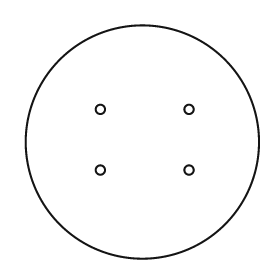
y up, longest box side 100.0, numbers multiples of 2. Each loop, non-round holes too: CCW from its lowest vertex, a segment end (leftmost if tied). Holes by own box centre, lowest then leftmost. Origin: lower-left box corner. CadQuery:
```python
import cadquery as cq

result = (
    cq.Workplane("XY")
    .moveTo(50.0, 50.0)
    .circle(50.0)
    .moveTo(32.0, 38.0)
    .circle(2.0)
    .moveTo(70.0, 38.0)
    .circle(2.0)
    .moveTo(32.0, 64.0)
    .circle(2.0)
    .moveTo(70.0, 64.0)
    .circle(2.0)
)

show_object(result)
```